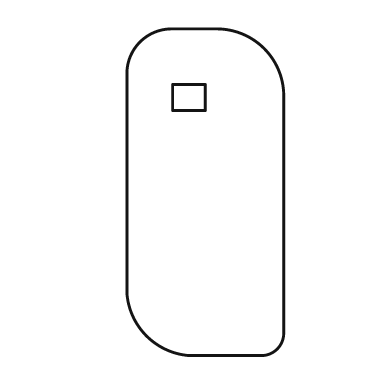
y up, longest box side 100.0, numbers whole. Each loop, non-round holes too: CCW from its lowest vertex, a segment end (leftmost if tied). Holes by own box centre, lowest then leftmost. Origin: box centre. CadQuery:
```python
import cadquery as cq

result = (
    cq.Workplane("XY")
    .moveTo(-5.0, -50.0)
    .lineTo(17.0, -50.0)
    .threePointArc((22.0, -48.0), (24.0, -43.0))
    .lineTo(24.0, 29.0)
    .threePointArc((18.0, 44.0), (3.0, 50.0))
    .lineTo(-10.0, 50.0)
    .threePointArc((-20.0, 46.0), (-24.0, 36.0))
    .lineTo(-24.0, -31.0)
    .threePointArc((-18.0, -44.0), (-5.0, -50.0))
    .close()
    .moveTo(-10.0, 25.0)
    .lineTo(0.0, 25.0)
    .lineTo(0.0, 33.0)
    .lineTo(-10.0, 33.0)
    .close()
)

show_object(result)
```